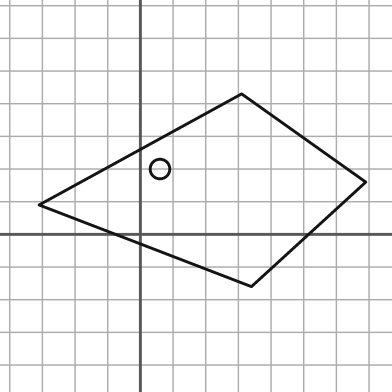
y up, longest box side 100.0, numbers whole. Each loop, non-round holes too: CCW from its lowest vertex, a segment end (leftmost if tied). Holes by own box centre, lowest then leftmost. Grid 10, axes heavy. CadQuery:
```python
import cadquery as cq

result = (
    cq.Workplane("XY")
    .moveTo(34.0, -16.0)
    .lineTo(69.0, 16.0)
    .lineTo(31.0, 43.0)
    .lineTo(-31.0, 9.0)
    .close()
    .moveTo(6.0, 20.0)
    .circle(3.0)
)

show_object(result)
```